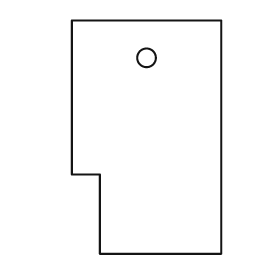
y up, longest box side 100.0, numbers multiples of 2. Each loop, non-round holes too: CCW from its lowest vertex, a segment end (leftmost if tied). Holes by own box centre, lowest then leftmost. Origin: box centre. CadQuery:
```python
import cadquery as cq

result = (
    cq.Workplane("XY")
    .moveTo(-20.0, -50.0)
    .lineTo(32.0, -50.0)
    .lineTo(32.0, 50.0)
    .lineTo(-32.0, 50.0)
    .lineTo(-32.0, -16.0)
    .lineTo(-20.0, -16.0)
    .close()
    .moveTo(0.0, 34.0)
    .circle(4.0)
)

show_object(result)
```